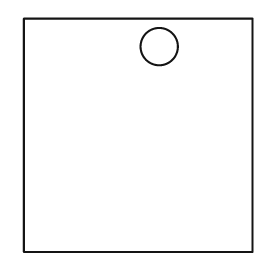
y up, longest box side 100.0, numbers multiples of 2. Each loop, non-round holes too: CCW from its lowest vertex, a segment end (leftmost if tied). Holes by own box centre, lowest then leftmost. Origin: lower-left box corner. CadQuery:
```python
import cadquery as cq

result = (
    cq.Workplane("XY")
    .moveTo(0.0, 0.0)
    .lineTo(98.0, 0.0)
    .lineTo(98.0, 100.0)
    .lineTo(0.0, 100.0)
    .close()
    .moveTo(58.0, 88.0)
    .circle(8.0)
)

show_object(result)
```